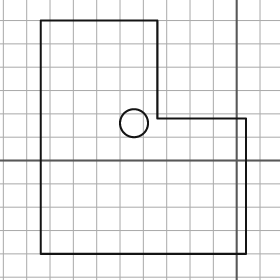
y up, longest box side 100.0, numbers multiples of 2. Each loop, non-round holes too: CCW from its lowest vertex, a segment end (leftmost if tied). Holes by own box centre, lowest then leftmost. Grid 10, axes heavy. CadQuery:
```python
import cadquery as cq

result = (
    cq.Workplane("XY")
    .moveTo(-84.0, -40.0)
    .lineTo(4.0, -40.0)
    .lineTo(4.0, 18.0)
    .lineTo(-34.0, 18.0)
    .lineTo(-34.0, 60.0)
    .lineTo(-84.0, 60.0)
    .close()
    .moveTo(-44.0, 16.0)
    .circle(6.0)
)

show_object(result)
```